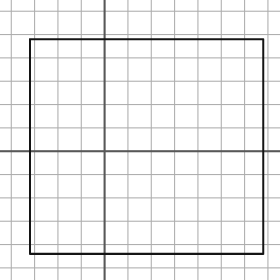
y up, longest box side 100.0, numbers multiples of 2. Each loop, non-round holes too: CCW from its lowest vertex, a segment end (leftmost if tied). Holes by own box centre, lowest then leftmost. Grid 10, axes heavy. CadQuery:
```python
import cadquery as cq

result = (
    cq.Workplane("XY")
    .moveTo(-32.0, -44.0)
    .lineTo(68.0, -44.0)
    .lineTo(68.0, 48.0)
    .lineTo(-32.0, 48.0)
    .close()
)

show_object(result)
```